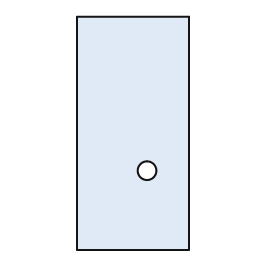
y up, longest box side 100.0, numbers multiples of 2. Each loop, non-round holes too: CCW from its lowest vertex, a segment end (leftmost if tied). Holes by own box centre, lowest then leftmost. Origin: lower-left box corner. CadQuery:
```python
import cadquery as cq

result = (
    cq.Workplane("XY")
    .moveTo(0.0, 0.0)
    .lineTo(48.0, 0.0)
    .lineTo(48.0, 100.0)
    .lineTo(0.0, 100.0)
    .close()
    .moveTo(30.0, 34.0)
    .circle(4.0)
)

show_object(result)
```